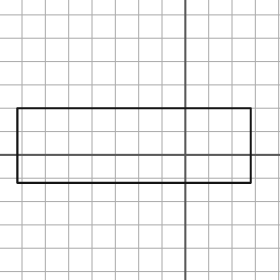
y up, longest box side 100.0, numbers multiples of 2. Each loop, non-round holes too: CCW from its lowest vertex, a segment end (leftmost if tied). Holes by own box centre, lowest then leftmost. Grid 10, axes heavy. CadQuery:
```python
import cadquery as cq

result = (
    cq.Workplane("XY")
    .moveTo(-72.0, -12.0)
    .lineTo(28.0, -12.0)
    .lineTo(28.0, 20.0)
    .lineTo(-72.0, 20.0)
    .close()
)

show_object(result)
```